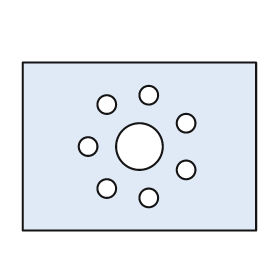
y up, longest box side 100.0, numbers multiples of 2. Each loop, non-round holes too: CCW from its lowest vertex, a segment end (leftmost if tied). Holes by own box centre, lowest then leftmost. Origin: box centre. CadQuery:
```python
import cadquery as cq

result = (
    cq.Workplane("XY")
    .moveTo(-50.0, -36.0)
    .lineTo(50.0, -36.0)
    .lineTo(50.0, 36.0)
    .lineTo(-50.0, 36.0)
    .close()
    .moveTo(4.0, -22.0)
    .circle(4.0)
    .moveTo(-14.0, -18.0)
    .circle(4.0)
    .moveTo(20.0, -10.0)
    .circle(4.0)
    .moveTo(-22.0, 0.0)
    .circle(4.0)
    .moveTo(0.0, 0.0)
    .circle(10.0)
    .moveTo(20.0, 10.0)
    .circle(4.0)
    .moveTo(-14.0, 18.0)
    .circle(4.0)
    .moveTo(4.0, 22.0)
    .circle(4.0)
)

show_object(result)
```